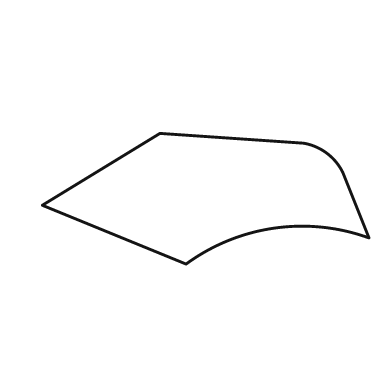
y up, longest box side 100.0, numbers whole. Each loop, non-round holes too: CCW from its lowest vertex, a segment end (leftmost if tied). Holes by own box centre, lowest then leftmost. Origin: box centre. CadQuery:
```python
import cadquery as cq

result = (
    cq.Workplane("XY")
    .moveTo(-6.0, -20.0)
    .threePointArc((21.0, -9.0), (50.0, -12.0))
    .lineTo(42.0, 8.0)
    .threePointArc((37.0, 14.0), (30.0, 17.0))
    .lineTo(-14.0, 20.0)
    .lineTo(-50.0, -2.0)
    .close()
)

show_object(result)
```